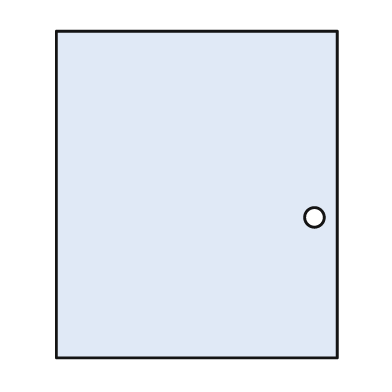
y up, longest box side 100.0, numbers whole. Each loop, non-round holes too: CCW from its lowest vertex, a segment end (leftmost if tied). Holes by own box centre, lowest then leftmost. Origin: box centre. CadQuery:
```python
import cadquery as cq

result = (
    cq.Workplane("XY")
    .moveTo(-43.0, -50.0)
    .lineTo(43.0, -50.0)
    .lineTo(43.0, 50.0)
    .lineTo(-43.0, 50.0)
    .close()
    .moveTo(36.0, -7.0)
    .circle(3.0)
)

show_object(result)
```